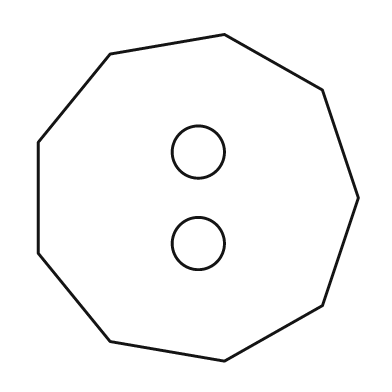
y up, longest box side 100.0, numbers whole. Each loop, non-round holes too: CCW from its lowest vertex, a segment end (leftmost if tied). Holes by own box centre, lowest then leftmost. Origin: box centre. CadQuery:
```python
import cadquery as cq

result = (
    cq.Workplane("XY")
    .moveTo(8.0, -50.0)
    .lineTo(38.0, -33.0)
    .lineTo(49.0, 0.0)
    .lineTo(38.0, 33.0)
    .lineTo(8.0, 50.0)
    .lineTo(-27.0, 44.0)
    .lineTo(-49.0, 17.0)
    .lineTo(-49.0, -17.0)
    .lineTo(-27.0, -44.0)
    .close()
    .moveTo(0.0, -14.0)
    .circle(8.0)
    .moveTo(0.0, 14.0)
    .circle(8.0)
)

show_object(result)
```